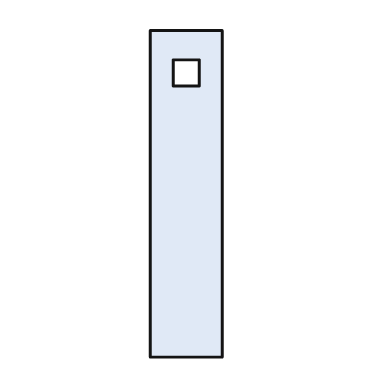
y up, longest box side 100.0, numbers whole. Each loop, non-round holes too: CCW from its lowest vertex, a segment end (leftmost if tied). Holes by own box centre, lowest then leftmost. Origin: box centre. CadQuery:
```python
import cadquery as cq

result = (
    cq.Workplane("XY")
    .moveTo(-11.0, -50.0)
    .lineTo(11.0, -50.0)
    .lineTo(11.0, 50.0)
    .lineTo(-11.0, 50.0)
    .close()
    .moveTo(-4.0, 33.0)
    .lineTo(4.0, 33.0)
    .lineTo(4.0, 41.0)
    .lineTo(-4.0, 41.0)
    .close()
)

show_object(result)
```